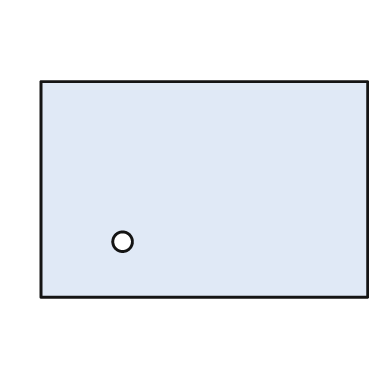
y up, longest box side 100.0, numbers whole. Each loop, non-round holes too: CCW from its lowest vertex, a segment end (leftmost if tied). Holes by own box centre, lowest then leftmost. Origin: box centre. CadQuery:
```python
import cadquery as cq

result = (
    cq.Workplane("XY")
    .moveTo(-50.0, -33.0)
    .lineTo(50.0, -33.0)
    .lineTo(50.0, 33.0)
    .lineTo(-50.0, 33.0)
    .close()
    .moveTo(-25.0, -16.0)
    .circle(3.0)
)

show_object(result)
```